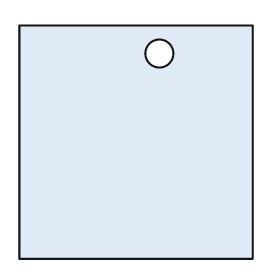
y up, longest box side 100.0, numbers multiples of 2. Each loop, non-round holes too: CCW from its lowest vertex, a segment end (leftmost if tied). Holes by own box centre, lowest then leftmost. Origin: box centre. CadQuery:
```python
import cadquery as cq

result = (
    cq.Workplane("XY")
    .moveTo(-50.0, -50.0)
    .lineTo(50.0, -50.0)
    .lineTo(50.0, 50.0)
    .lineTo(-50.0, 50.0)
    .close()
    .moveTo(10.0, 38.0)
    .circle(6.0)
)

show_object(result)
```